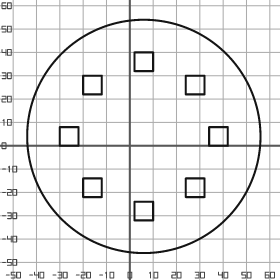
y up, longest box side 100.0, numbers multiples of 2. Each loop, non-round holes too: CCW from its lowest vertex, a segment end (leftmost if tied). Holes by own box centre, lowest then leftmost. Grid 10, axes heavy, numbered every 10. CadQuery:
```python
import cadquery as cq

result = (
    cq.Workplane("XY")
    .moveTo(6.0, 4.0)
    .circle(50.0)
    .moveTo(2.0, -32.0)
    .lineTo(10.0, -32.0)
    .lineTo(10.0, -24.0)
    .lineTo(2.0, -24.0)
    .close()
    .moveTo(-20.0, -22.0)
    .lineTo(-12.0, -22.0)
    .lineTo(-12.0, -14.0)
    .lineTo(-20.0, -14.0)
    .close()
    .moveTo(24.0, -22.0)
    .lineTo(32.0, -22.0)
    .lineTo(32.0, -14.0)
    .lineTo(24.0, -14.0)
    .close()
    .moveTo(-30.0, 0.0)
    .lineTo(-22.0, 0.0)
    .lineTo(-22.0, 8.0)
    .lineTo(-30.0, 8.0)
    .close()
    .moveTo(34.0, 0.0)
    .lineTo(42.0, 0.0)
    .lineTo(42.0, 8.0)
    .lineTo(34.0, 8.0)
    .close()
    .moveTo(-20.0, 22.0)
    .lineTo(-12.0, 22.0)
    .lineTo(-12.0, 30.0)
    .lineTo(-20.0, 30.0)
    .close()
    .moveTo(24.0, 22.0)
    .lineTo(32.0, 22.0)
    .lineTo(32.0, 30.0)
    .lineTo(24.0, 30.0)
    .close()
    .moveTo(2.0, 32.0)
    .lineTo(10.0, 32.0)
    .lineTo(10.0, 40.0)
    .lineTo(2.0, 40.0)
    .close()
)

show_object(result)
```